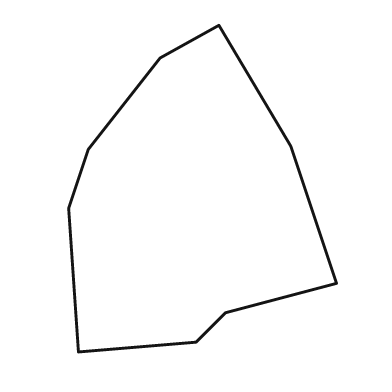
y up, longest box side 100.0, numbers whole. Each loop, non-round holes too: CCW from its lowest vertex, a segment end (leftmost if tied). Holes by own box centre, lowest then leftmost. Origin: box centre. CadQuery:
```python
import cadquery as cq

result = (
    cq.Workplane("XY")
    .moveTo(-38.0, -50.0)
    .lineTo(-2.0, -47.0)
    .lineTo(7.0, -38.0)
    .lineTo(41.0, -29.0)
    .lineTo(27.0, 13.0)
    .lineTo(5.0, 50.0)
    .lineTo(-13.0, 40.0)
    .lineTo(-35.0, 12.0)
    .lineTo(-41.0, -6.0)
    .close()
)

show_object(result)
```